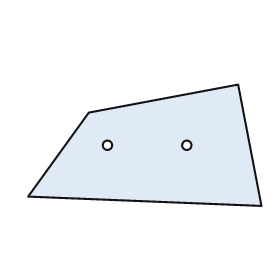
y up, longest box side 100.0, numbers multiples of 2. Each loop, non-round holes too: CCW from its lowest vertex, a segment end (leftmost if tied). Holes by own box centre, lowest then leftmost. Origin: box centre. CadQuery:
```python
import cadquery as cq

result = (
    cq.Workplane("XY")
    .moveTo(50.0, -26.0)
    .lineTo(40.0, 26.0)
    .lineTo(-24.0, 14.0)
    .lineTo(-50.0, -22.0)
    .close()
    .moveTo(-16.0, 0.0)
    .circle(2.0)
    .moveTo(18.0, 0.0)
    .circle(2.0)
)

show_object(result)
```